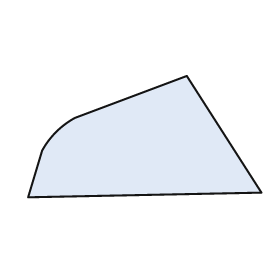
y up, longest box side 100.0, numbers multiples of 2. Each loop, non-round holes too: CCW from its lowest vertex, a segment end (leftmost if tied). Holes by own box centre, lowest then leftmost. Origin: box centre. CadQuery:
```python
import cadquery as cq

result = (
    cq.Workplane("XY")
    .moveTo(-50.0, -26.0)
    .lineTo(50.0, -24.0)
    .lineTo(18.0, 26.0)
    .lineTo(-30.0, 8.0)
    .threePointArc((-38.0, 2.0), (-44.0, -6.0))
    .close()
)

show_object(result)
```